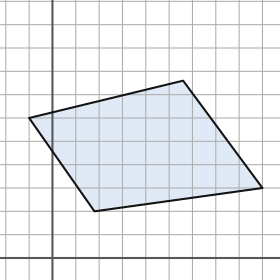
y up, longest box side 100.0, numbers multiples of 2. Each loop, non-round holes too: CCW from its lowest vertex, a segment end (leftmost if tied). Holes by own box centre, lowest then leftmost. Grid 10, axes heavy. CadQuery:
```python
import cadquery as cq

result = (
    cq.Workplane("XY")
    .moveTo(18.0, 20.0)
    .lineTo(90.0, 30.0)
    .lineTo(56.0, 76.0)
    .lineTo(-10.0, 60.0)
    .close()
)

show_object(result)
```